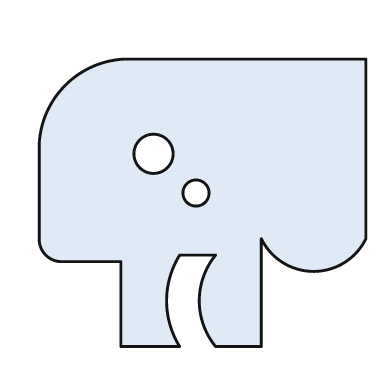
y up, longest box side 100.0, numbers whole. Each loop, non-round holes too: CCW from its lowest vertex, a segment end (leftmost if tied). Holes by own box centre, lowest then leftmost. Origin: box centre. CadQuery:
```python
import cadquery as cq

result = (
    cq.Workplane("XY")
    .moveTo(-25.0, -44.0)
    .lineTo(-7.0, -44.0)
    .threePointArc((-11.0, -30.0), (-7.0, -16.0))
    .lineTo(4.0, -16.0)
    .threePointArc((-1.0, -30.0), (4.0, -44.0))
    .lineTo(18.0, -44.0)
    .lineTo(18.0, -11.0)
    .threePointArc((34.0, -21.0), (50.0, -11.0))
    .lineTo(50.0, 44.0)
    .lineTo(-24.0, 44.0)
    .threePointArc((-42.0, 36.0), (-50.0, 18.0))
    .lineTo(-50.0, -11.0)
    .threePointArc((-48.0, -16.0), (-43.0, -18.0))
    .lineTo(-25.0, -18.0)
    .close()
    .moveTo(-2.0, 3.0)
    .circle(4.0)
    .moveTo(-15.0, 15.0)
    .circle(6.0)
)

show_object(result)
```